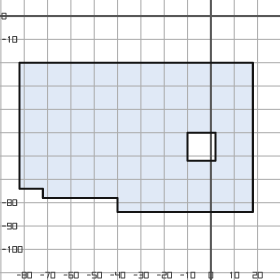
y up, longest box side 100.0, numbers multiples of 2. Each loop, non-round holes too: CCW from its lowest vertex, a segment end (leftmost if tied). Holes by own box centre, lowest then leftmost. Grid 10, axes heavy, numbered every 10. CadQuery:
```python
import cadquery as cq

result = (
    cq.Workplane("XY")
    .moveTo(-40.0, -84.0)
    .lineTo(18.0, -84.0)
    .lineTo(18.0, -20.0)
    .lineTo(-82.0, -20.0)
    .lineTo(-82.0, -74.0)
    .lineTo(-72.0, -74.0)
    .lineTo(-72.0, -78.0)
    .lineTo(-40.0, -78.0)
    .close()
    .moveTo(-10.0, -62.0)
    .lineTo(2.0, -62.0)
    .lineTo(2.0, -50.0)
    .lineTo(-10.0, -50.0)
    .close()
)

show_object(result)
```